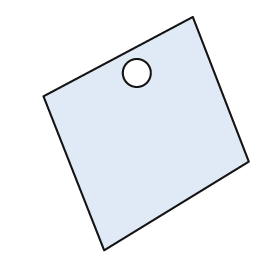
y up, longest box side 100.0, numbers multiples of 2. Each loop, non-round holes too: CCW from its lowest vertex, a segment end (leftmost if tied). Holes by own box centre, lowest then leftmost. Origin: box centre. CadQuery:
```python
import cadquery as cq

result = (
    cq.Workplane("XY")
    .moveTo(-18.0, -50.0)
    .lineTo(44.0, -12.0)
    .lineTo(20.0, 50.0)
    .lineTo(-44.0, 16.0)
    .close()
    .moveTo(-4.0, 26.0)
    .circle(6.0)
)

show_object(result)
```